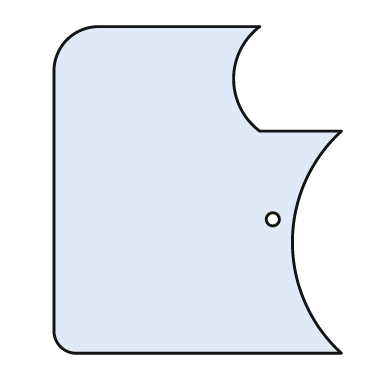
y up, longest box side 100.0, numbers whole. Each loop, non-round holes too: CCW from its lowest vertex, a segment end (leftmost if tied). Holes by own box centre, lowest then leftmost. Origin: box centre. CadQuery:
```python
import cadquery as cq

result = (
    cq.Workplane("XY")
    .moveTo(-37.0, -50.0)
    .lineTo(44.0, -50.0)
    .threePointArc((29.0, -16.0), (44.0, 18.0))
    .lineTo(19.0, 18.0)
    .threePointArc((11.0, 34.0), (19.0, 50.0))
    .lineTo(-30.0, 50.0)
    .threePointArc((-40.0, 46.0), (-44.0, 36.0))
    .lineTo(-44.0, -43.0)
    .threePointArc((-42.0, -48.0), (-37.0, -50.0))
    .close()
    .moveTo(23.0, -9.0)
    .circle(2.0)
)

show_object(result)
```